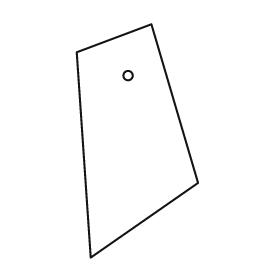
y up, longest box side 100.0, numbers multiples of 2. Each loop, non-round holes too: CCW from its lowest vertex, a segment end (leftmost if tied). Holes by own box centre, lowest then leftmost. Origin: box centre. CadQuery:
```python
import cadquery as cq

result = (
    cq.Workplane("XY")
    .moveTo(-20.0, -50.0)
    .lineTo(26.0, -18.0)
    .lineTo(6.0, 50.0)
    .lineTo(-26.0, 38.0)
    .close()
    .moveTo(-4.0, 28.0)
    .circle(2.0)
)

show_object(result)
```